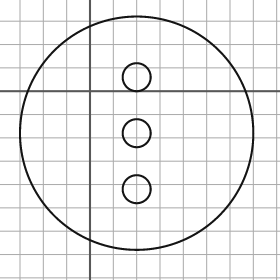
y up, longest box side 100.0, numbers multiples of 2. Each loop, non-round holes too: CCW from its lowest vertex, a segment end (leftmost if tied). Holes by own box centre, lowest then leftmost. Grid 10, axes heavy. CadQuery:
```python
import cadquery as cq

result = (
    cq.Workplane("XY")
    .moveTo(20.0, -18.0)
    .circle(50.0)
    .moveTo(20.0, -42.0)
    .circle(6.0)
    .moveTo(20.0, -18.0)
    .circle(6.0)
    .moveTo(20.0, 6.0)
    .circle(6.0)
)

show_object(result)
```